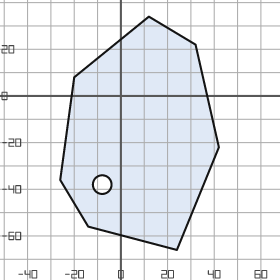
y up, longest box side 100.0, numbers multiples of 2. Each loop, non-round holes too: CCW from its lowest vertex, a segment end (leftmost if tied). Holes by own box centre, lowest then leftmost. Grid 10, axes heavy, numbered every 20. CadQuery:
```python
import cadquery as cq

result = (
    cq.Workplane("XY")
    .moveTo(24.0, -66.0)
    .lineTo(42.0, -22.0)
    .lineTo(32.0, 22.0)
    .lineTo(12.0, 34.0)
    .lineTo(-20.0, 8.0)
    .lineTo(-26.0, -36.0)
    .lineTo(-14.0, -56.0)
    .close()
    .moveTo(-8.0, -38.0)
    .circle(4.0)
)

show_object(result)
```